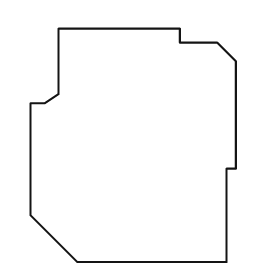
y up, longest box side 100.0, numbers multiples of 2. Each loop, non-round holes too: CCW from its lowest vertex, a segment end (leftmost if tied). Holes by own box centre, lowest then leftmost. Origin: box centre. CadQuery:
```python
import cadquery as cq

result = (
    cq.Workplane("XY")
    .moveTo(-24.0, -50.0)
    .lineTo(40.0, -50.0)
    .lineTo(40.0, -10.0)
    .lineTo(44.0, -10.0)
    .lineTo(44.0, 36.0)
    .lineTo(36.0, 44.0)
    .lineTo(20.0, 44.0)
    .lineTo(20.0, 50.0)
    .lineTo(-32.0, 50.0)
    .lineTo(-32.0, 22.0)
    .lineTo(-38.0, 18.0)
    .lineTo(-44.0, 18.0)
    .lineTo(-44.0, -30.0)
    .close()
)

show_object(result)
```